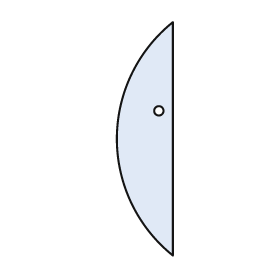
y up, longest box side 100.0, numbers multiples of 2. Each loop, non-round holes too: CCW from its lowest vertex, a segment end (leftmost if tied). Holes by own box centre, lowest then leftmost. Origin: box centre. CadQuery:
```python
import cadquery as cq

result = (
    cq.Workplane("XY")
    .moveTo(12.0, -50.0)
    .lineTo(12.0, 50.0)
    .threePointArc((-12.0, 0.0), (12.0, -50.0))
    .close()
    .moveTo(6.0, 12.0)
    .circle(2.0)
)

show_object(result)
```